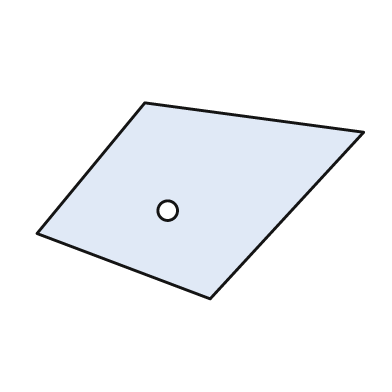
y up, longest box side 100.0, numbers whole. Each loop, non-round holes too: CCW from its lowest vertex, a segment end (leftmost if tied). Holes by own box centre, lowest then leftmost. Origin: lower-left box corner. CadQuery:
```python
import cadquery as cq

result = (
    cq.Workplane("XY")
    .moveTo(53.0, 0.0)
    .lineTo(100.0, 51.0)
    .lineTo(33.0, 60.0)
    .lineTo(0.0, 20.0)
    .close()
    .moveTo(40.0, 27.0)
    .circle(3.0)
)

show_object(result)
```